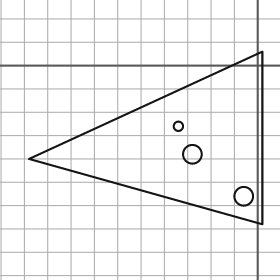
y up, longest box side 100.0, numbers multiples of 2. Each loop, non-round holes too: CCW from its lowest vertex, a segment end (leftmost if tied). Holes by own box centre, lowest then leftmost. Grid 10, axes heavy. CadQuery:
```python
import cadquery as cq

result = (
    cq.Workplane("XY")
    .moveTo(2.0, -68.0)
    .lineTo(2.0, 6.0)
    .lineTo(-98.0, -40.0)
    .close()
    .moveTo(-6.0, -56.0)
    .circle(4.0)
    .moveTo(-28.0, -38.0)
    .circle(4.0)
    .moveTo(-34.0, -26.0)
    .circle(2.0)
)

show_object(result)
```